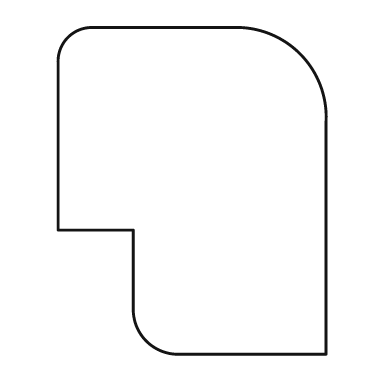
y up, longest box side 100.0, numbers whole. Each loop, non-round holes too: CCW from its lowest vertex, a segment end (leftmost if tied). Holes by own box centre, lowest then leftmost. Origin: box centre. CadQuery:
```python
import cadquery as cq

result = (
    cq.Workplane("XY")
    .moveTo(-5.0, -50.0)
    .lineTo(41.0, -50.0)
    .lineTo(41.0, 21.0)
    .threePointArc((33.0, 42.0), (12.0, 50.0))
    .lineTo(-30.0, 50.0)
    .threePointArc((-38.0, 47.0), (-41.0, 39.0))
    .lineTo(-41.0, -12.0)
    .lineTo(-18.0, -12.0)
    .lineTo(-18.0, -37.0)
    .threePointArc((-14.0, -46.0), (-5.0, -50.0))
    .close()
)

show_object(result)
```